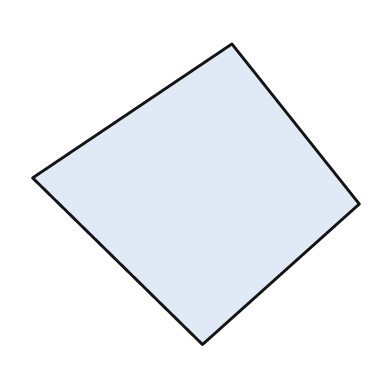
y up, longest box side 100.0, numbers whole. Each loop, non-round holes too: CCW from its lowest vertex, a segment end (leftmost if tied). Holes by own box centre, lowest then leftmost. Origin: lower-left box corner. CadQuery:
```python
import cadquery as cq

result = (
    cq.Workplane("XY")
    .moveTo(52.0, 0.0)
    .lineTo(100.0, 43.0)
    .lineTo(61.0, 92.0)
    .lineTo(0.0, 51.0)
    .close()
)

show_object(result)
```